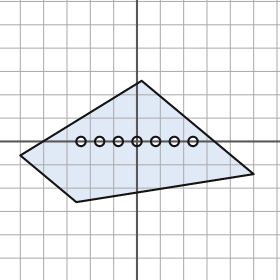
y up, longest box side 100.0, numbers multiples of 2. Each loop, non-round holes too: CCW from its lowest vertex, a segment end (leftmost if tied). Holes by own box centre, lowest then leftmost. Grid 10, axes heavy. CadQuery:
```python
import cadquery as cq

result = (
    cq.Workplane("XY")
    .moveTo(-26.0, -26.0)
    .lineTo(50.0, -14.0)
    .lineTo(2.0, 26.0)
    .lineTo(-50.0, -6.0)
    .close()
    .moveTo(-24.0, 0.0)
    .circle(2.0)
    .moveTo(-16.0, 0.0)
    .circle(2.0)
    .moveTo(-8.0, 0.0)
    .circle(2.0)
    .moveTo(0.0, 0.0)
    .circle(2.0)
    .moveTo(8.0, 0.0)
    .circle(2.0)
    .moveTo(16.0, 0.0)
    .circle(2.0)
    .moveTo(24.0, 0.0)
    .circle(2.0)
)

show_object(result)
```